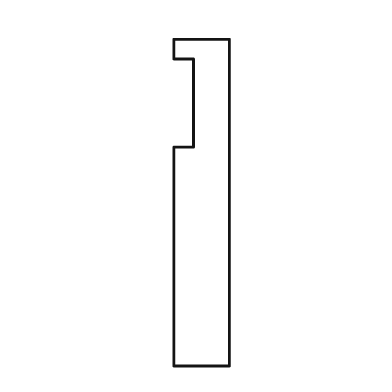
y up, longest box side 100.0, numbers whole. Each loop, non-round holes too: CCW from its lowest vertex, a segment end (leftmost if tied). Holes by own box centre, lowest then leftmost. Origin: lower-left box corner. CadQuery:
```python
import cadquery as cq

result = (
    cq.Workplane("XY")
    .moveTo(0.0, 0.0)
    .lineTo(17.0, 0.0)
    .lineTo(17.0, 100.0)
    .lineTo(0.0, 100.0)
    .lineTo(0.0, 94.0)
    .lineTo(6.0, 94.0)
    .lineTo(6.0, 67.0)
    .lineTo(0.0, 67.0)
    .close()
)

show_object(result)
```